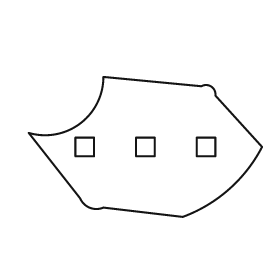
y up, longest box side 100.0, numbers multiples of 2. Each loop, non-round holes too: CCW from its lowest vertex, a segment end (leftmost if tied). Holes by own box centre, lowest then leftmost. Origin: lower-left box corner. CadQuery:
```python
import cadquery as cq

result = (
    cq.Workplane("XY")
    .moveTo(66.0, 0.0)
    .threePointArc((86.0, 12.0), (100.0, 30.0))
    .lineTo(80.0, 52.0)
    .threePointArc((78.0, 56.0), (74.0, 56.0))
    .lineTo(32.0, 60.0)
    .threePointArc((22.0, 40.0), (0.0, 36.0))
    .lineTo(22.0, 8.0)
    .threePointArc((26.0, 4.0), (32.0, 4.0))
    .close()
    .moveTo(20.0, 26.0)
    .lineTo(28.0, 26.0)
    .lineTo(28.0, 34.0)
    .lineTo(20.0, 34.0)
    .close()
    .moveTo(46.0, 26.0)
    .lineTo(54.0, 26.0)
    .lineTo(54.0, 34.0)
    .lineTo(46.0, 34.0)
    .close()
    .moveTo(72.0, 26.0)
    .lineTo(80.0, 26.0)
    .lineTo(80.0, 34.0)
    .lineTo(72.0, 34.0)
    .close()
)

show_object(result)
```